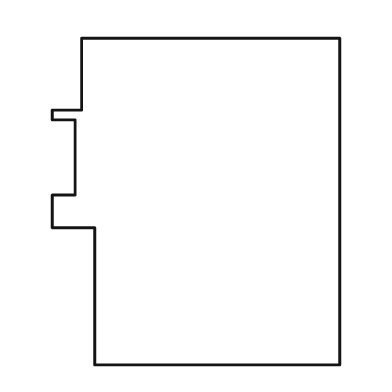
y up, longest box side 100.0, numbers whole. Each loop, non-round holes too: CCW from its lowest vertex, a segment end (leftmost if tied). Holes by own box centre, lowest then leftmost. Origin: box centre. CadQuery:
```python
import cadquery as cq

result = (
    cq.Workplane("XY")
    .moveTo(-31.0, -50.0)
    .lineTo(44.0, -50.0)
    .lineTo(44.0, 50.0)
    .lineTo(-35.0, 50.0)
    .lineTo(-35.0, 28.0)
    .lineTo(-44.0, 28.0)
    .lineTo(-44.0, 25.0)
    .lineTo(-37.0, 25.0)
    .lineTo(-37.0, 2.0)
    .lineTo(-44.0, 2.0)
    .lineTo(-44.0, -8.0)
    .lineTo(-31.0, -8.0)
    .close()
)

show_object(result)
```